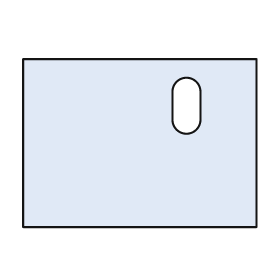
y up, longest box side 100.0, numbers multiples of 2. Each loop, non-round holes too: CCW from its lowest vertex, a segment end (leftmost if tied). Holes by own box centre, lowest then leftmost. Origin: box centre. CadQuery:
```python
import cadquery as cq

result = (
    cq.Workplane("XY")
    .moveTo(-50.0, -36.0)
    .lineTo(50.0, -36.0)
    .lineTo(50.0, 36.0)
    .lineTo(-50.0, 36.0)
    .close()
    .moveTo(14.0, 10.0)
    .threePointArc((20.0, 4.0), (26.0, 10.0))
    .lineTo(26.0, 22.0)
    .threePointArc((20.0, 28.0), (14.0, 22.0))
    .close()
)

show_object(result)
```